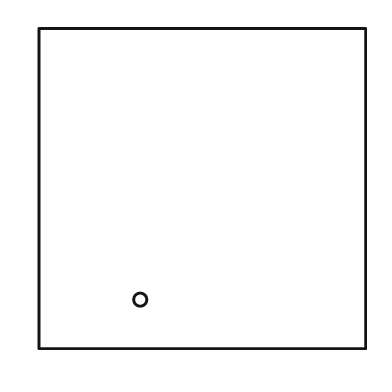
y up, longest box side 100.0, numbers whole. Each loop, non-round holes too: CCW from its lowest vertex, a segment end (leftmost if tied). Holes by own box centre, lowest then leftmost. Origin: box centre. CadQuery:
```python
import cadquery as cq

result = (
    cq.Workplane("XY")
    .moveTo(-50.0, -49.0)
    .lineTo(50.0, -49.0)
    .lineTo(50.0, 49.0)
    .lineTo(-50.0, 49.0)
    .close()
    .moveTo(-19.0, -34.0)
    .circle(2.0)
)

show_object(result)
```